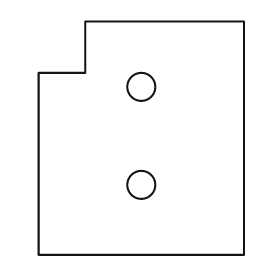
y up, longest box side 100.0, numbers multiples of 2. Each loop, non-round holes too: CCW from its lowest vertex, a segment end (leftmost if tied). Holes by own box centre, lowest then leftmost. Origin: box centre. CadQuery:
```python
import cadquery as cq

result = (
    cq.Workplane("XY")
    .moveTo(-44.0, -50.0)
    .lineTo(44.0, -50.0)
    .lineTo(44.0, 50.0)
    .lineTo(-24.0, 50.0)
    .lineTo(-24.0, 28.0)
    .lineTo(-44.0, 28.0)
    .close()
    .moveTo(0.0, -20.0)
    .circle(6.0)
    .moveTo(0.0, 22.0)
    .circle(6.0)
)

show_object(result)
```